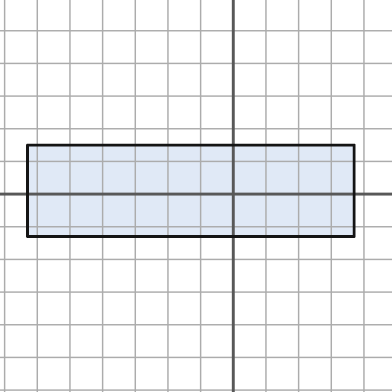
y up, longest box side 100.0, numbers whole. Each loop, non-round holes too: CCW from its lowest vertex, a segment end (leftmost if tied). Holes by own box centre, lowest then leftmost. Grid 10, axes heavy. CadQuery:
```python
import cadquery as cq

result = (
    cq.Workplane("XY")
    .moveTo(-63.0, -13.0)
    .lineTo(37.0, -13.0)
    .lineTo(37.0, 15.0)
    .lineTo(-63.0, 15.0)
    .close()
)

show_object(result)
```